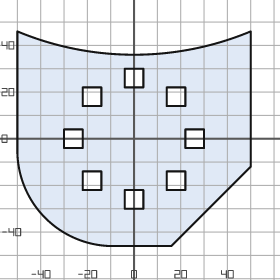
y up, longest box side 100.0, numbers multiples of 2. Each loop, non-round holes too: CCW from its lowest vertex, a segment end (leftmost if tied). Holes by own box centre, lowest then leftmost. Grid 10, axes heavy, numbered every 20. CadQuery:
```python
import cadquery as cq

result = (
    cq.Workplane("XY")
    .moveTo(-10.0, -46.0)
    .lineTo(16.0, -46.0)
    .lineTo(50.0, -12.0)
    .lineTo(50.0, 46.0)
    .threePointArc((0.0, 36.0), (-50.0, 46.0))
    .lineTo(-50.0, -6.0)
    .threePointArc((-38.0, -34.0), (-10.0, -46.0))
    .close()
    .moveTo(-4.0, -30.0)
    .lineTo(4.0, -30.0)
    .lineTo(4.0, -22.0)
    .lineTo(-4.0, -22.0)
    .close()
    .moveTo(-22.0, -22.0)
    .lineTo(-14.0, -22.0)
    .lineTo(-14.0, -14.0)
    .lineTo(-22.0, -14.0)
    .close()
    .moveTo(14.0, -22.0)
    .lineTo(22.0, -22.0)
    .lineTo(22.0, -14.0)
    .lineTo(14.0, -14.0)
    .close()
    .moveTo(-30.0, -4.0)
    .lineTo(-22.0, -4.0)
    .lineTo(-22.0, 4.0)
    .lineTo(-30.0, 4.0)
    .close()
    .moveTo(22.0, -4.0)
    .lineTo(30.0, -4.0)
    .lineTo(30.0, 4.0)
    .lineTo(22.0, 4.0)
    .close()
    .moveTo(-22.0, 14.0)
    .lineTo(-14.0, 14.0)
    .lineTo(-14.0, 22.0)
    .lineTo(-22.0, 22.0)
    .close()
    .moveTo(14.0, 14.0)
    .lineTo(22.0, 14.0)
    .lineTo(22.0, 22.0)
    .lineTo(14.0, 22.0)
    .close()
    .moveTo(-4.0, 22.0)
    .lineTo(4.0, 22.0)
    .lineTo(4.0, 30.0)
    .lineTo(-4.0, 30.0)
    .close()
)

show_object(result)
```